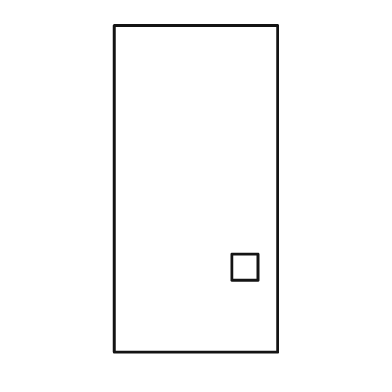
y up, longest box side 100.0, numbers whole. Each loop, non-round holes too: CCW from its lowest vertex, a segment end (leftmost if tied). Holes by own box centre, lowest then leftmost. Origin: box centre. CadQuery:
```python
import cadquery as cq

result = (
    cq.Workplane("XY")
    .moveTo(-25.0, -50.0)
    .lineTo(25.0, -50.0)
    .lineTo(25.0, 50.0)
    .lineTo(-25.0, 50.0)
    .close()
    .moveTo(11.0, -28.0)
    .lineTo(19.0, -28.0)
    .lineTo(19.0, -20.0)
    .lineTo(11.0, -20.0)
    .close()
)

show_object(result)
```